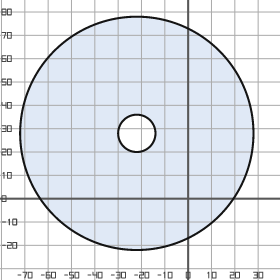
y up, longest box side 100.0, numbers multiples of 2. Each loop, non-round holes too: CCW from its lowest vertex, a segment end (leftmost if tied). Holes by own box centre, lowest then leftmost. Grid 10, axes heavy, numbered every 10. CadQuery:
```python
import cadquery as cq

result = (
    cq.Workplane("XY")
    .moveTo(-22.0, 28.0)
    .circle(50.0)
    .moveTo(-22.0, 28.0)
    .circle(8.0)
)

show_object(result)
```